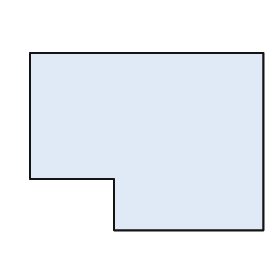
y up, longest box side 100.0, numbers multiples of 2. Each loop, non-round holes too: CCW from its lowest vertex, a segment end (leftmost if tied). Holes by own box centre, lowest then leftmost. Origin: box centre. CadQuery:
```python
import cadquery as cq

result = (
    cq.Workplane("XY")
    .moveTo(-14.0, -38.0)
    .lineTo(50.0, -38.0)
    .lineTo(50.0, 38.0)
    .lineTo(-50.0, 38.0)
    .lineTo(-50.0, -16.0)
    .lineTo(-14.0, -16.0)
    .close()
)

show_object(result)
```